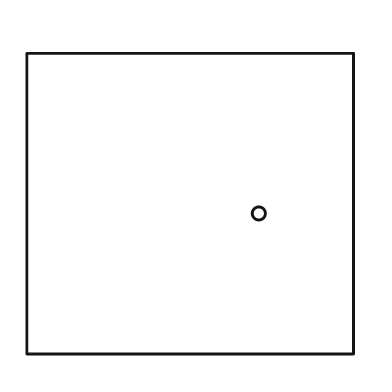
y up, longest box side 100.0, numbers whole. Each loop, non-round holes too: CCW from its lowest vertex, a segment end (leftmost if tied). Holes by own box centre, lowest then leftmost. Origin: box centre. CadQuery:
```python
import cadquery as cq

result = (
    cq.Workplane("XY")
    .moveTo(-50.0, -46.0)
    .lineTo(50.0, -46.0)
    .lineTo(50.0, 46.0)
    .lineTo(-50.0, 46.0)
    .close()
    .moveTo(21.0, -3.0)
    .circle(2.0)
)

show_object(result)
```